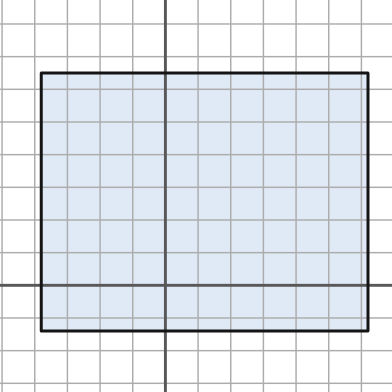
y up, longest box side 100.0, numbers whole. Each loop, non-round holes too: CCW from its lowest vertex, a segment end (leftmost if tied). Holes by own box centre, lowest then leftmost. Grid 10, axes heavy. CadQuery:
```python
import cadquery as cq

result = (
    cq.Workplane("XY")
    .moveTo(-38.0, -14.0)
    .lineTo(62.0, -14.0)
    .lineTo(62.0, 65.0)
    .lineTo(-38.0, 65.0)
    .close()
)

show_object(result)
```